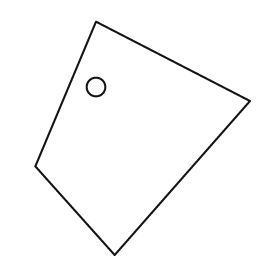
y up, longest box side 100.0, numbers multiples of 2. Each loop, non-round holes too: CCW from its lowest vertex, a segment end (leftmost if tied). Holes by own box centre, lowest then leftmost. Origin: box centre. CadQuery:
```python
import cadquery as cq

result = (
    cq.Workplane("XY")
    .moveTo(-12.0, -50.0)
    .lineTo(46.0, 16.0)
    .lineTo(-20.0, 50.0)
    .lineTo(-46.0, -12.0)
    .close()
    .moveTo(-20.0, 22.0)
    .circle(4.0)
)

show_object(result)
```